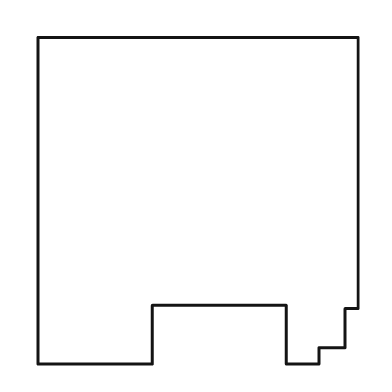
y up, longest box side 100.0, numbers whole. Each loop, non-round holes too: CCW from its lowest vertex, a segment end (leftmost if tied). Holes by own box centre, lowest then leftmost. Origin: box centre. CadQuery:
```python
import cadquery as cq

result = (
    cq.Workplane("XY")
    .moveTo(-49.0, -50.0)
    .lineTo(-14.0, -50.0)
    .lineTo(-14.0, -32.0)
    .lineTo(27.0, -32.0)
    .lineTo(27.0, -50.0)
    .lineTo(37.0, -50.0)
    .lineTo(37.0, -45.0)
    .lineTo(45.0, -45.0)
    .lineTo(45.0, -33.0)
    .lineTo(49.0, -33.0)
    .lineTo(49.0, 50.0)
    .lineTo(-49.0, 50.0)
    .close()
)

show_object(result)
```